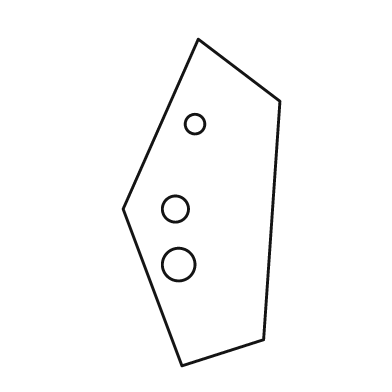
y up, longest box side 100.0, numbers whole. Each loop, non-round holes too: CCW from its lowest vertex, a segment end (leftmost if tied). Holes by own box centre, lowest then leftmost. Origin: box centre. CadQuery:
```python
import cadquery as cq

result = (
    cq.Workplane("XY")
    .moveTo(-6.0, -50.0)
    .lineTo(19.0, -42.0)
    .lineTo(24.0, 31.0)
    .lineTo(-1.0, 50.0)
    .lineTo(-24.0, -2.0)
    .close()
    .moveTo(-7.0, -19.0)
    .circle(5.0)
    .moveTo(-8.0, -2.0)
    .circle(4.0)
    .moveTo(-2.0, 24.0)
    .circle(3.0)
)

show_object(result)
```